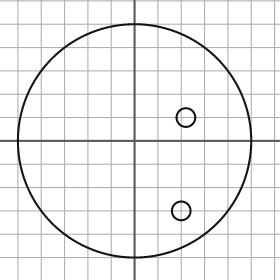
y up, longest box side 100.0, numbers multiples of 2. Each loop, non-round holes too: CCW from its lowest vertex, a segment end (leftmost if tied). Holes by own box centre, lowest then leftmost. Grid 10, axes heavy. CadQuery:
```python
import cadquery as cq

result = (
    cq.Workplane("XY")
    .moveTo(0.0, 0.0)
    .circle(50.0)
    .moveTo(20.0, -30.0)
    .circle(4.0)
    .moveTo(22.0, 10.0)
    .circle(4.0)
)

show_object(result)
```